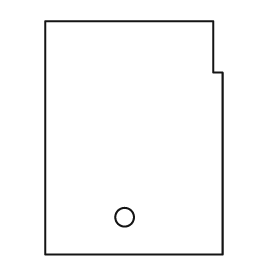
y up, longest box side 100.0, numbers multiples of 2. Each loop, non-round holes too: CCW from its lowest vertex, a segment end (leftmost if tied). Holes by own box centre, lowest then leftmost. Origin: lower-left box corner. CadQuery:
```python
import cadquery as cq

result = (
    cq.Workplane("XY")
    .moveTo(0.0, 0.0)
    .lineTo(76.0, 0.0)
    .lineTo(76.0, 78.0)
    .lineTo(72.0, 78.0)
    .lineTo(72.0, 100.0)
    .lineTo(0.0, 100.0)
    .close()
    .moveTo(34.0, 16.0)
    .circle(4.0)
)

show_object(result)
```